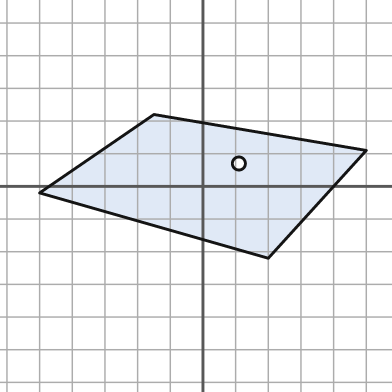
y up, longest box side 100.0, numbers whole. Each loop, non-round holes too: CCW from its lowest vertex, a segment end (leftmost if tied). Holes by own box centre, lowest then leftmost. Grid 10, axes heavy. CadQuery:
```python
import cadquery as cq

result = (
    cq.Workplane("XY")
    .moveTo(20.0, -22.0)
    .lineTo(50.0, 11.0)
    .lineTo(-15.0, 22.0)
    .lineTo(-50.0, -2.0)
    .close()
    .moveTo(11.0, 7.0)
    .circle(2.0)
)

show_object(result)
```